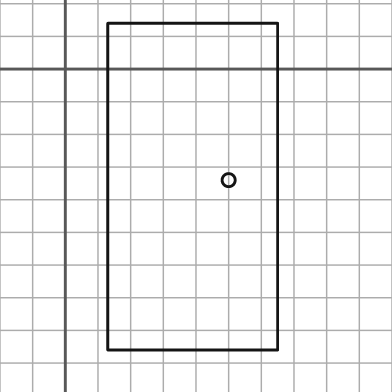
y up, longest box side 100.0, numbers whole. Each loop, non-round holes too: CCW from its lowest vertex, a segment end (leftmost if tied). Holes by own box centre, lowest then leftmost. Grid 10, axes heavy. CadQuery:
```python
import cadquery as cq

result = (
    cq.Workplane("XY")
    .moveTo(13.0, -86.0)
    .lineTo(65.0, -86.0)
    .lineTo(65.0, 14.0)
    .lineTo(13.0, 14.0)
    .close()
    .moveTo(50.0, -34.0)
    .circle(2.0)
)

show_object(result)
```